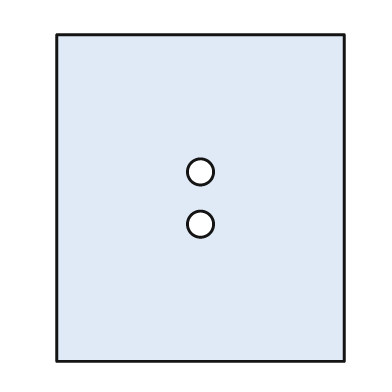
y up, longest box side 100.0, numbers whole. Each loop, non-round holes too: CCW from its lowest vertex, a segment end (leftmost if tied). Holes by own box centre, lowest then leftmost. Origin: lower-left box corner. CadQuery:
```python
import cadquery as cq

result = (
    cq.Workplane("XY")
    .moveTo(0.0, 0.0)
    .lineTo(88.0, 0.0)
    .lineTo(88.0, 100.0)
    .lineTo(0.0, 100.0)
    .close()
    .moveTo(44.0, 42.0)
    .circle(4.0)
    .moveTo(44.0, 58.0)
    .circle(4.0)
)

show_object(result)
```